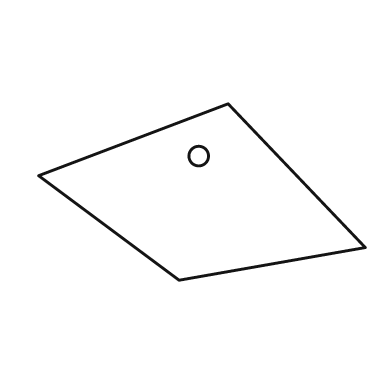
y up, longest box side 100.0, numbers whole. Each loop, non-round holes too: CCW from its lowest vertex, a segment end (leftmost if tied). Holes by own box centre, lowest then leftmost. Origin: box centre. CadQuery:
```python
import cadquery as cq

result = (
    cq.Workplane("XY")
    .moveTo(-7.0, -27.0)
    .lineTo(50.0, -17.0)
    .lineTo(8.0, 27.0)
    .lineTo(-50.0, 5.0)
    .close()
    .moveTo(-1.0, 11.0)
    .circle(3.0)
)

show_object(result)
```